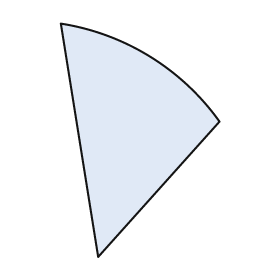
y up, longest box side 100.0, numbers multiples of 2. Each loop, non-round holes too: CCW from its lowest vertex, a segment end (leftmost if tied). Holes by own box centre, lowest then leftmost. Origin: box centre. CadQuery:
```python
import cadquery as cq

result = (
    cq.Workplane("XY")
    .moveTo(-18.0, -50.0)
    .lineTo(34.0, 8.0)
    .threePointArc((4.0, 36.0), (-34.0, 50.0))
    .close()
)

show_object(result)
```